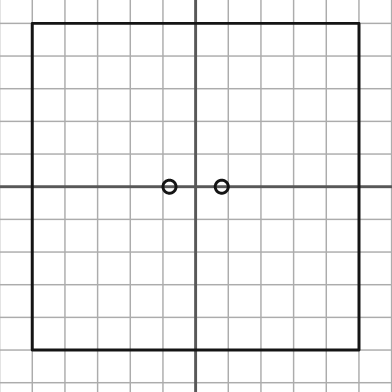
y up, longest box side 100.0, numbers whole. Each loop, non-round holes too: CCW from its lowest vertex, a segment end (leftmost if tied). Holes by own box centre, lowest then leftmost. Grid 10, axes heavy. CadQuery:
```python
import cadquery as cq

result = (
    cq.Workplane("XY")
    .moveTo(-50.0, -50.0)
    .lineTo(50.0, -50.0)
    .lineTo(50.0, 50.0)
    .lineTo(-50.0, 50.0)
    .close()
    .moveTo(-8.0, 0.0)
    .circle(2.0)
    .moveTo(8.0, 0.0)
    .circle(2.0)
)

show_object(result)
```